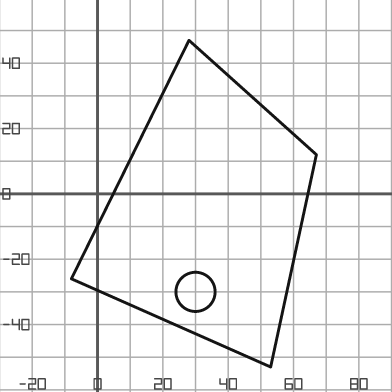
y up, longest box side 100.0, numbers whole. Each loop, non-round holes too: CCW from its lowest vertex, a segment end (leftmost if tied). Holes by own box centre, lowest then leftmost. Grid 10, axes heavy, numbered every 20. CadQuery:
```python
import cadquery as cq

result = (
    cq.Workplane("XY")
    .moveTo(53.0, -53.0)
    .lineTo(67.0, 12.0)
    .lineTo(28.0, 47.0)
    .lineTo(-8.0, -26.0)
    .close()
    .moveTo(30.0, -30.0)
    .circle(6.0)
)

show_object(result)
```